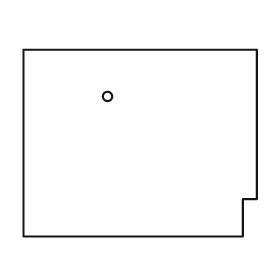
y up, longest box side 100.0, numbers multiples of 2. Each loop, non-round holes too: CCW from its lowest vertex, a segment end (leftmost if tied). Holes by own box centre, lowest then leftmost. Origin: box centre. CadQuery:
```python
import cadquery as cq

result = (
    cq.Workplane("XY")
    .moveTo(-50.0, -40.0)
    .lineTo(44.0, -40.0)
    .lineTo(44.0, -24.0)
    .lineTo(50.0, -24.0)
    .lineTo(50.0, 40.0)
    .lineTo(-50.0, 40.0)
    .close()
    .moveTo(-14.0, 20.0)
    .circle(2.0)
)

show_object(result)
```